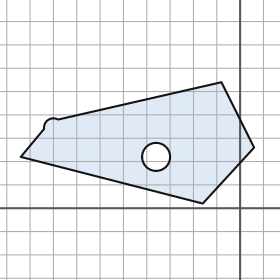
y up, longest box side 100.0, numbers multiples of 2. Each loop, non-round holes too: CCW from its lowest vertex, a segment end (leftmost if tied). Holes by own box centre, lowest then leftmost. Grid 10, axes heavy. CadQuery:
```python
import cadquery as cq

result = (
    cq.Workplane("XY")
    .moveTo(-16.0, 2.0)
    .lineTo(6.0, 26.0)
    .lineTo(-8.0, 54.0)
    .lineTo(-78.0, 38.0)
    .threePointArc((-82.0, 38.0), (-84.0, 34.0))
    .lineTo(-94.0, 22.0)
    .close()
    .moveTo(-36.0, 22.0)
    .circle(6.0)
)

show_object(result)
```